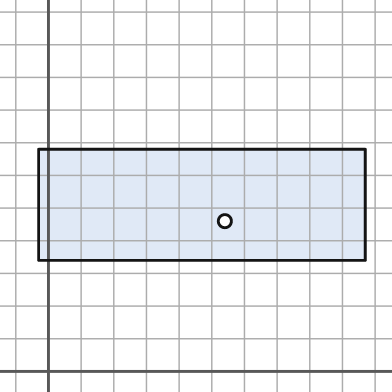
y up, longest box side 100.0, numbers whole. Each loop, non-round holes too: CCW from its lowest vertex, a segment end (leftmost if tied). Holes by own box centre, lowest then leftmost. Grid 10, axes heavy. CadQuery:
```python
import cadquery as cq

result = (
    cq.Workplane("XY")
    .moveTo(-3.0, 34.0)
    .lineTo(97.0, 34.0)
    .lineTo(97.0, 68.0)
    .lineTo(-3.0, 68.0)
    .close()
    .moveTo(54.0, 46.0)
    .circle(2.0)
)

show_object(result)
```